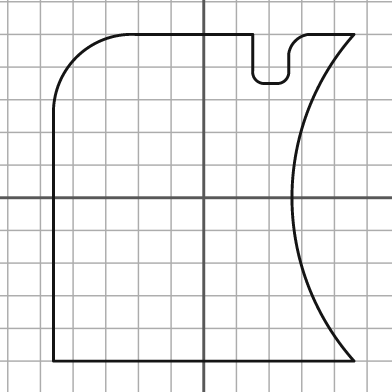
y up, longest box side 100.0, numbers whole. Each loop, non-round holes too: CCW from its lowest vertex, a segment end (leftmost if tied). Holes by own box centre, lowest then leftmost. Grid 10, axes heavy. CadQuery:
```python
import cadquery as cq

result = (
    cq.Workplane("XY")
    .moveTo(-46.0, -50.0)
    .lineTo(46.0, -50.0)
    .threePointArc((27.0, 0.0), (46.0, 50.0))
    .lineTo(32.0, 50.0)
    .threePointArc((28.0, 48.0), (26.0, 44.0))
    .lineTo(26.0, 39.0)
    .threePointArc((25.0, 36.0), (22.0, 35.0))
    .lineTo(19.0, 35.0)
    .threePointArc((16.0, 36.0), (15.0, 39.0))
    .lineTo(15.0, 50.0)
    .lineTo(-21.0, 50.0)
    .threePointArc((-39.0, 43.0), (-46.0, 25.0))
    .close()
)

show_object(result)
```